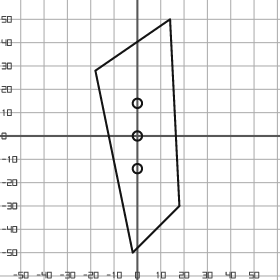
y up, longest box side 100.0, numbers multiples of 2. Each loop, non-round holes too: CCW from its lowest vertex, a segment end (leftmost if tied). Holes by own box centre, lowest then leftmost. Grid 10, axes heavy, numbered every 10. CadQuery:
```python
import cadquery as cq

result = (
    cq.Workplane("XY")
    .moveTo(-2.0, -50.0)
    .lineTo(18.0, -30.0)
    .lineTo(14.0, 50.0)
    .lineTo(-18.0, 28.0)
    .close()
    .moveTo(0.0, -14.0)
    .circle(2.0)
    .moveTo(0.0, 0.0)
    .circle(2.0)
    .moveTo(0.0, 14.0)
    .circle(2.0)
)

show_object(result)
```